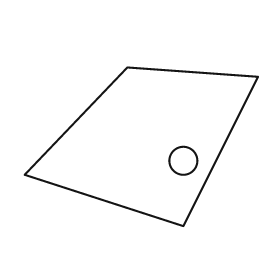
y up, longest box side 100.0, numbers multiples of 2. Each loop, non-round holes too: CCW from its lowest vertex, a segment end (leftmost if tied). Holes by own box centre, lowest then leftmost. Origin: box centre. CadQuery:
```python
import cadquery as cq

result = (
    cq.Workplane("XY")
    .moveTo(18.0, -34.0)
    .lineTo(50.0, 30.0)
    .lineTo(-6.0, 34.0)
    .lineTo(-50.0, -12.0)
    .close()
    .moveTo(18.0, -6.0)
    .circle(6.0)
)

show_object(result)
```